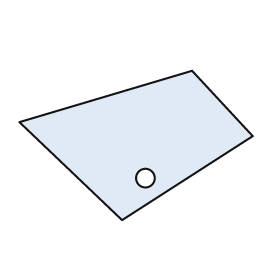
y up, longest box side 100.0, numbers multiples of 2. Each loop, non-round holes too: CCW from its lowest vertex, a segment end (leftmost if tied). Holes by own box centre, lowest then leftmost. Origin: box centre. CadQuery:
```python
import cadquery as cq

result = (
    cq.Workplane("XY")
    .moveTo(-6.0, -32.0)
    .lineTo(50.0, 4.0)
    .lineTo(24.0, 32.0)
    .lineTo(-50.0, 10.0)
    .close()
    .moveTo(4.0, -14.0)
    .circle(4.0)
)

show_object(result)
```